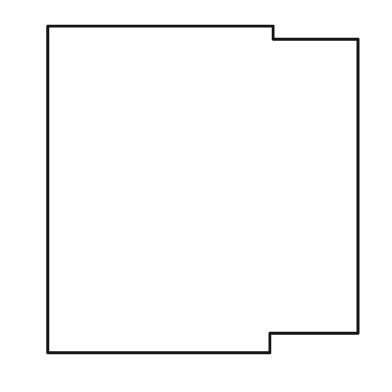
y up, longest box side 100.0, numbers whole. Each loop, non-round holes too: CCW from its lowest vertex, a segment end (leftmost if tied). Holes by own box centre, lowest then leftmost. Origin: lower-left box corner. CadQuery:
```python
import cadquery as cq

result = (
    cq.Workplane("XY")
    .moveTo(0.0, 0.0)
    .lineTo(68.0, 0.0)
    .lineTo(68.0, 6.0)
    .lineTo(95.0, 6.0)
    .lineTo(95.0, 96.0)
    .lineTo(69.0, 96.0)
    .lineTo(69.0, 100.0)
    .lineTo(0.0, 100.0)
    .close()
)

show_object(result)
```